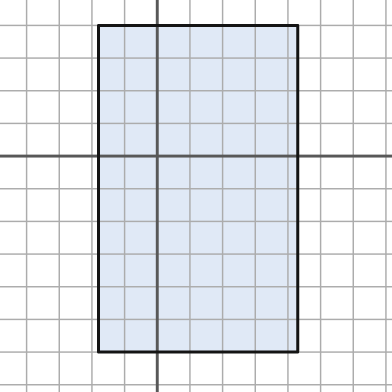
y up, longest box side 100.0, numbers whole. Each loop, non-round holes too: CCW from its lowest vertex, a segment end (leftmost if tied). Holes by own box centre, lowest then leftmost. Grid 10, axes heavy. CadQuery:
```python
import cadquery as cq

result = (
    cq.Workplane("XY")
    .moveTo(-18.0, -60.0)
    .lineTo(43.0, -60.0)
    .lineTo(43.0, 40.0)
    .lineTo(-18.0, 40.0)
    .close()
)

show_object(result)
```